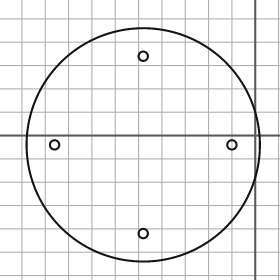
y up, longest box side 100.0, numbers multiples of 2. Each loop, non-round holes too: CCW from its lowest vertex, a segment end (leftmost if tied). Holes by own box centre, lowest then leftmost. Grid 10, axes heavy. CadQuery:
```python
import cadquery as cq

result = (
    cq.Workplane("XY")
    .moveTo(-48.0, -4.0)
    .circle(50.0)
    .moveTo(-48.0, -42.0)
    .circle(2.0)
    .moveTo(-86.0, -4.0)
    .circle(2.0)
    .moveTo(-10.0, -4.0)
    .circle(2.0)
    .moveTo(-48.0, 34.0)
    .circle(2.0)
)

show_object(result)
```